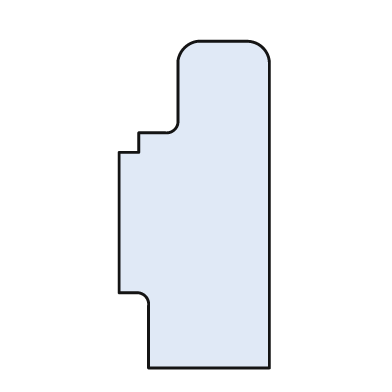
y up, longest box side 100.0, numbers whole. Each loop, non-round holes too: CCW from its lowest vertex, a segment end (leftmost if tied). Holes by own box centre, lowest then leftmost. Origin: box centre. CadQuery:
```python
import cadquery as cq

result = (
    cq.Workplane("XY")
    .moveTo(-14.0, -50.0)
    .lineTo(23.0, -50.0)
    .lineTo(23.0, 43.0)
    .threePointArc((21.0, 48.0), (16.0, 50.0))
    .lineTo(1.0, 50.0)
    .threePointArc((-3.0, 48.0), (-5.0, 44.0))
    .lineTo(-5.0, 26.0)
    .threePointArc((-6.0, 23.0), (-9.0, 22.0))
    .lineTo(-17.0, 22.0)
    .lineTo(-17.0, 16.0)
    .lineTo(-23.0, 16.0)
    .lineTo(-23.0, -27.0)
    .lineTo(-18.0, -27.0)
    .threePointArc((-15.0, -28.0), (-14.0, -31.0))
    .close()
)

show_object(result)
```